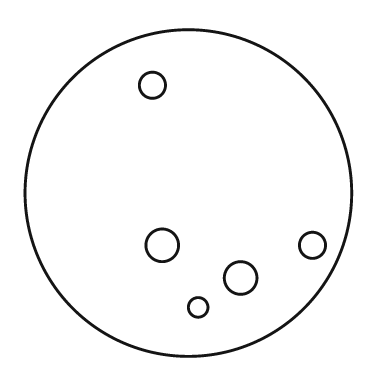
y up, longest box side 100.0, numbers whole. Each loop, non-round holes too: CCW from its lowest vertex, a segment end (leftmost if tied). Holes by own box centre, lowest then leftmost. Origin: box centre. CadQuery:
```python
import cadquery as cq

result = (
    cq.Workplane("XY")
    .moveTo(0.0, 0.0)
    .circle(50.0)
    .moveTo(3.0, -35.0)
    .circle(3.0)
    .moveTo(16.0, -26.0)
    .circle(5.0)
    .moveTo(-8.0, -16.0)
    .circle(5.0)
    .moveTo(38.0, -16.0)
    .circle(4.0)
    .moveTo(-11.0, 33.0)
    .circle(4.0)
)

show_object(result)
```